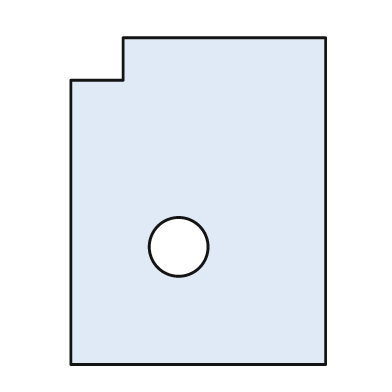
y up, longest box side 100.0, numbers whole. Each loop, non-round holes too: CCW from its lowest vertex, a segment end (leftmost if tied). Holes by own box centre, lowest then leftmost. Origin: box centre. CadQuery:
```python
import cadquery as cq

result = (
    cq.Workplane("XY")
    .moveTo(-39.0, -50.0)
    .lineTo(39.0, -50.0)
    .lineTo(39.0, 50.0)
    .lineTo(-23.0, 50.0)
    .lineTo(-23.0, 37.0)
    .lineTo(-39.0, 37.0)
    .close()
    .moveTo(-6.0, -14.0)
    .circle(9.0)
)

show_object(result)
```